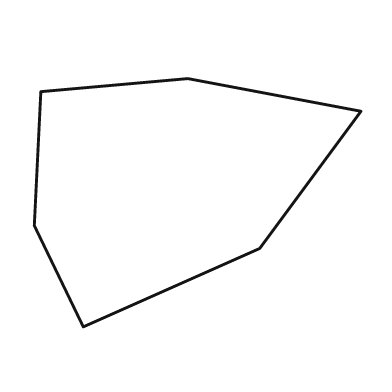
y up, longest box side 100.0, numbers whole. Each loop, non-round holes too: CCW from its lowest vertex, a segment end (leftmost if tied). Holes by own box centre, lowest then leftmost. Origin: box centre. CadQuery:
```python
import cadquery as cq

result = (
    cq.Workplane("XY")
    .moveTo(-35.0, -38.0)
    .lineTo(19.0, -14.0)
    .lineTo(50.0, 28.0)
    .lineTo(-3.0, 38.0)
    .lineTo(-48.0, 34.0)
    .lineTo(-50.0, -7.0)
    .close()
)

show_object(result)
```